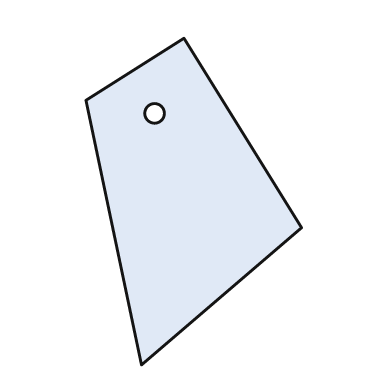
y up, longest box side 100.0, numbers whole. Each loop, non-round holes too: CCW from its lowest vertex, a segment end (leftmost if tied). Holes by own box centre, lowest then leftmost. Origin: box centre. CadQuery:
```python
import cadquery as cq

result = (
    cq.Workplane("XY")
    .moveTo(-16.0, -50.0)
    .lineTo(33.0, -8.0)
    .lineTo(-3.0, 50.0)
    .lineTo(-33.0, 31.0)
    .close()
    .moveTo(-12.0, 27.0)
    .circle(3.0)
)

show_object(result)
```